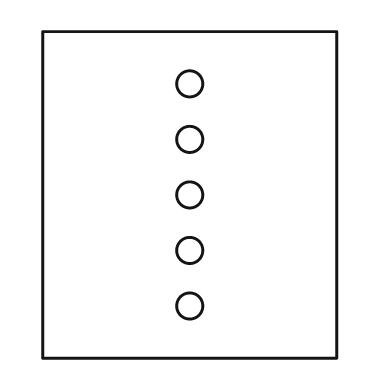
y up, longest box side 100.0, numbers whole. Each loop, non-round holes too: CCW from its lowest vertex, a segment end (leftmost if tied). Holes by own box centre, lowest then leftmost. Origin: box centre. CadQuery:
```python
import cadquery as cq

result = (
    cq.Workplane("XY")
    .moveTo(-45.0, -50.0)
    .lineTo(45.0, -50.0)
    .lineTo(45.0, 50.0)
    .lineTo(-45.0, 50.0)
    .close()
    .moveTo(0.0, -34.0)
    .circle(4.0)
    .moveTo(0.0, -17.0)
    .circle(4.0)
    .moveTo(0.0, 0.0)
    .circle(4.0)
    .moveTo(0.0, 17.0)
    .circle(4.0)
    .moveTo(0.0, 34.0)
    .circle(4.0)
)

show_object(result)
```